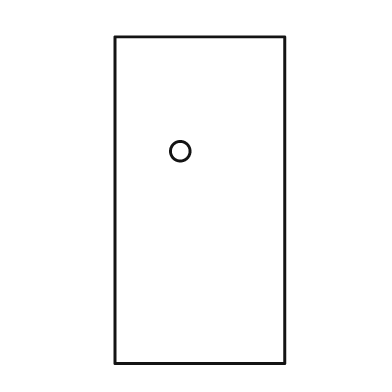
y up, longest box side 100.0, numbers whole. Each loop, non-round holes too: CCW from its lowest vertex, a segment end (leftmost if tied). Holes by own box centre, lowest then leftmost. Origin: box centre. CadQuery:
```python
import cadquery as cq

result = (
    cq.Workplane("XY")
    .moveTo(-26.0, -50.0)
    .lineTo(26.0, -50.0)
    .lineTo(26.0, 50.0)
    .lineTo(-26.0, 50.0)
    .close()
    .moveTo(-6.0, 15.0)
    .circle(3.0)
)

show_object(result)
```